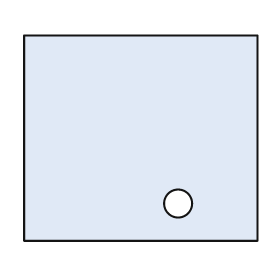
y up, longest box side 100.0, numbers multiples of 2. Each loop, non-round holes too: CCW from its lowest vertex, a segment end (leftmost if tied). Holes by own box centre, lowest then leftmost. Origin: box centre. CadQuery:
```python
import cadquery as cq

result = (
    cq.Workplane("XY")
    .moveTo(-50.0, -44.0)
    .lineTo(50.0, -44.0)
    .lineTo(50.0, 44.0)
    .lineTo(-50.0, 44.0)
    .close()
    .moveTo(16.0, -28.0)
    .circle(6.0)
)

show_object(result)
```